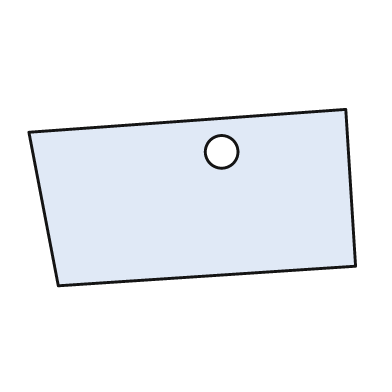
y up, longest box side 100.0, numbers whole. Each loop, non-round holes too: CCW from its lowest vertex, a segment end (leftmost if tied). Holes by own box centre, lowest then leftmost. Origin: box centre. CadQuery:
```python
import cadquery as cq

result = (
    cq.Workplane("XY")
    .moveTo(-41.0, -27.0)
    .lineTo(50.0, -21.0)
    .lineTo(47.0, 27.0)
    .lineTo(-50.0, 20.0)
    .close()
    .moveTo(9.0, 14.0)
    .circle(5.0)
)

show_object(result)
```